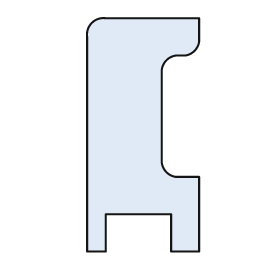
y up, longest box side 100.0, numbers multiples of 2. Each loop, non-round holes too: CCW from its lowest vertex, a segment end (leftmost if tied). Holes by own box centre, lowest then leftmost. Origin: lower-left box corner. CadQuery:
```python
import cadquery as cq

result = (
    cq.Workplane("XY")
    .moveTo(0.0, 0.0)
    .lineTo(8.0, 0.0)
    .lineTo(8.0, 16.0)
    .lineTo(36.0, 16.0)
    .lineTo(36.0, 0.0)
    .lineTo(48.0, 0.0)
    .lineTo(48.0, 32.0)
    .lineTo(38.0, 32.0)
    .threePointArc((34.0, 34.0), (32.0, 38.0))
    .lineTo(32.0, 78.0)
    .threePointArc((34.0, 82.0), (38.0, 84.0))
    .lineTo(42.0, 84.0)
    .threePointArc((46.0, 86.0), (48.0, 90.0))
    .lineTo(48.0, 100.0)
    .lineTo(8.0, 100.0)
    .threePointArc((2.0, 98.0), (0.0, 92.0))
    .close()
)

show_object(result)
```